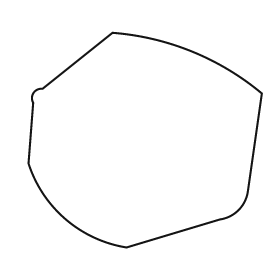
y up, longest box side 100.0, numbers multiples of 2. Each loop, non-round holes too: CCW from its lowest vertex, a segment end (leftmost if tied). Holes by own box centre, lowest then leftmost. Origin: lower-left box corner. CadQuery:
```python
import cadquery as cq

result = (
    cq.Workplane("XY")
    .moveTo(42.0, 0.0)
    .lineTo(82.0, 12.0)
    .threePointArc((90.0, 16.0), (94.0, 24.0))
    .lineTo(100.0, 66.0)
    .threePointArc((70.0, 84.0), (36.0, 92.0))
    .lineTo(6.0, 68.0)
    .threePointArc((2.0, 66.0), (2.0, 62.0))
    .lineTo(0.0, 36.0)
    .threePointArc((16.0, 12.0), (42.0, 0.0))
    .close()
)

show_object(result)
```